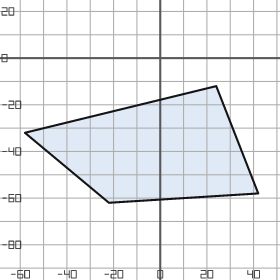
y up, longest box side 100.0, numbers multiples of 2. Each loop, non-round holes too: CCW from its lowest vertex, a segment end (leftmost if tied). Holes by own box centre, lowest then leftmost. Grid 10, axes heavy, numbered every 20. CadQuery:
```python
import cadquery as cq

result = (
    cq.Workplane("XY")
    .moveTo(-22.0, -62.0)
    .lineTo(42.0, -58.0)
    .lineTo(24.0, -12.0)
    .lineTo(-58.0, -32.0)
    .close()
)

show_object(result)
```